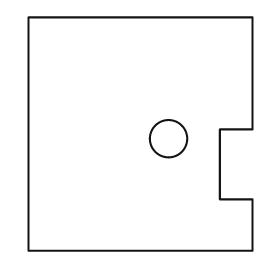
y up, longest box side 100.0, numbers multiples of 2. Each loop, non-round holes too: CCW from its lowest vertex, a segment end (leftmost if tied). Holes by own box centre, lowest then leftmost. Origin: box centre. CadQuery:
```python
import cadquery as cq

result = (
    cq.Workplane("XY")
    .moveTo(-48.0, -50.0)
    .lineTo(48.0, -50.0)
    .lineTo(48.0, -28.0)
    .lineTo(34.0, -28.0)
    .lineTo(34.0, 2.0)
    .lineTo(48.0, 2.0)
    .lineTo(48.0, 50.0)
    .lineTo(-48.0, 50.0)
    .close()
    .moveTo(12.0, -2.0)
    .circle(8.0)
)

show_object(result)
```